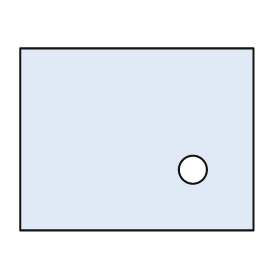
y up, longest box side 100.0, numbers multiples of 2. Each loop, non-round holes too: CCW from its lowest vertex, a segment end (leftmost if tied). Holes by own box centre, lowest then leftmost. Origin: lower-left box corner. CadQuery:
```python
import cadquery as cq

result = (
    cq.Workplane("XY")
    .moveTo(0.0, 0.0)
    .lineTo(100.0, 0.0)
    .lineTo(100.0, 78.0)
    .lineTo(0.0, 78.0)
    .close()
    .moveTo(74.0, 26.0)
    .circle(6.0)
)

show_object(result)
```